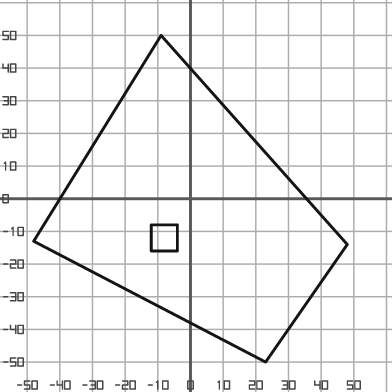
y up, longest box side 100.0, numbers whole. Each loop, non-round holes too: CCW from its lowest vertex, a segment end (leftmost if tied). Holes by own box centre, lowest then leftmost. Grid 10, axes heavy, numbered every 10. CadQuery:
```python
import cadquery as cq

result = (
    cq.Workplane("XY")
    .moveTo(23.0, -50.0)
    .lineTo(48.0, -14.0)
    .lineTo(-9.0, 50.0)
    .lineTo(-48.0, -13.0)
    .close()
    .moveTo(-12.0, -16.0)
    .lineTo(-4.0, -16.0)
    .lineTo(-4.0, -8.0)
    .lineTo(-12.0, -8.0)
    .close()
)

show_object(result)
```